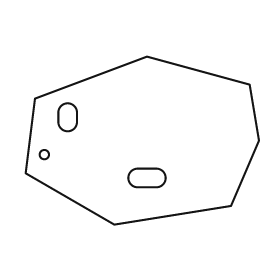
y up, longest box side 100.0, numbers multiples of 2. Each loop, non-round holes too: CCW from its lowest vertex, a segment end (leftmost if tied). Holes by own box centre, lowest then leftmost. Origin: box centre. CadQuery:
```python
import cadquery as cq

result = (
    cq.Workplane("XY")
    .moveTo(-12.0, -36.0)
    .lineTo(38.0, -28.0)
    .lineTo(50.0, 0.0)
    .lineTo(46.0, 24.0)
    .lineTo(2.0, 36.0)
    .lineTo(-46.0, 18.0)
    .lineTo(-50.0, -14.0)
    .close()
    .moveTo(-2.0, -20.0)
    .lineTo(6.0, -20.0)
    .threePointArc((10.0, -16.0), (6.0, -12.0))
    .lineTo(-2.0, -12.0)
    .threePointArc((-6.0, -16.0), (-2.0, -20.0))
    .close()
    .moveTo(-42.0, -6.0)
    .circle(2.0)
    .moveTo(-36.0, 8.0)
    .threePointArc((-32.0, 4.0), (-28.0, 8.0))
    .lineTo(-28.0, 12.0)
    .threePointArc((-32.0, 16.0), (-36.0, 12.0))
    .close()
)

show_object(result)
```